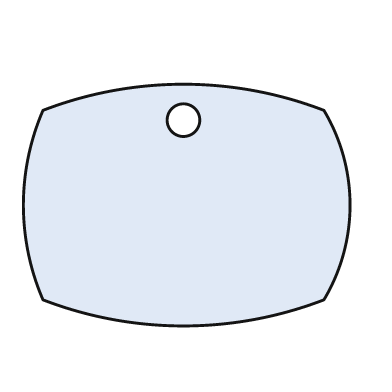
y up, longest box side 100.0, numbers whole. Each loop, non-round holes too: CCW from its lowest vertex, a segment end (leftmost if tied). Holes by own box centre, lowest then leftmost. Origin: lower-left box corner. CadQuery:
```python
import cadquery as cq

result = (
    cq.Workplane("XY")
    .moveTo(6.0, 8.0)
    .threePointArc((49.0, 0.0), (92.0, 8.0))
    .threePointArc((100.0, 37.0), (92.0, 66.0))
    .threePointArc((49.0, 74.0), (6.0, 66.0))
    .threePointArc((0.0, 37.0), (6.0, 8.0))
    .close()
    .moveTo(49.0, 63.0)
    .circle(5.0)
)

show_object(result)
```